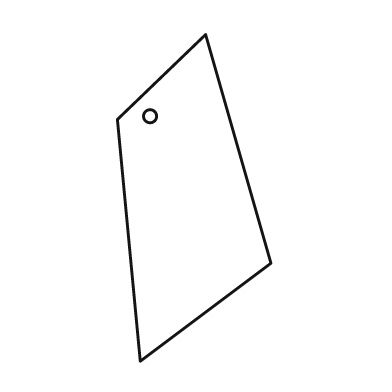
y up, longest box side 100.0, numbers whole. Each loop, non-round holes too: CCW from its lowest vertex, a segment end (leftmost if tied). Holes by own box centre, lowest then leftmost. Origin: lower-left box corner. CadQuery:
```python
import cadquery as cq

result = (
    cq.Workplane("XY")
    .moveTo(7.0, 0.0)
    .lineTo(47.0, 30.0)
    .lineTo(27.0, 100.0)
    .lineTo(0.0, 74.0)
    .close()
    .moveTo(10.0, 75.0)
    .circle(2.0)
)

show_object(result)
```